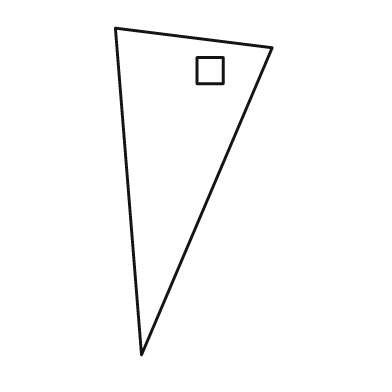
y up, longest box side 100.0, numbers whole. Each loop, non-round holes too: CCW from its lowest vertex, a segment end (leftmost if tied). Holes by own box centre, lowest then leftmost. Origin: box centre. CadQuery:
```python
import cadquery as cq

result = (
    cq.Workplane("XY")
    .moveTo(-16.0, -50.0)
    .lineTo(24.0, 44.0)
    .lineTo(-24.0, 50.0)
    .close()
    .moveTo(1.0, 33.0)
    .lineTo(9.0, 33.0)
    .lineTo(9.0, 41.0)
    .lineTo(1.0, 41.0)
    .close()
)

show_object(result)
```